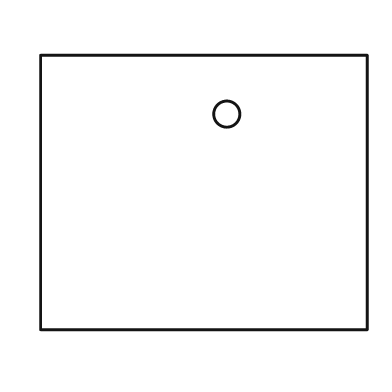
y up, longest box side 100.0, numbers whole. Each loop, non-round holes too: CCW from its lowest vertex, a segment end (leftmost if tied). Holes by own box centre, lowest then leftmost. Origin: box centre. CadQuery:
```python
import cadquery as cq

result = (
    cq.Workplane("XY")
    .moveTo(-50.0, -42.0)
    .lineTo(50.0, -42.0)
    .lineTo(50.0, 42.0)
    .lineTo(-50.0, 42.0)
    .close()
    .moveTo(7.0, 24.0)
    .circle(4.0)
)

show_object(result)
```